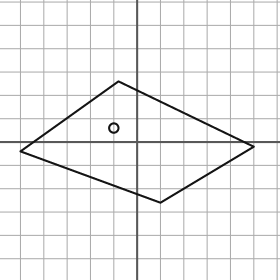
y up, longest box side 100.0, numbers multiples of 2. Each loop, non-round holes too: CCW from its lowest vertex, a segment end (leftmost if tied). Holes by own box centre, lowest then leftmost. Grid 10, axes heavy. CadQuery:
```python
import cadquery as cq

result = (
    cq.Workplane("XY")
    .moveTo(10.0, -26.0)
    .lineTo(50.0, -2.0)
    .lineTo(-8.0, 26.0)
    .lineTo(-50.0, -4.0)
    .close()
    .moveTo(-10.0, 6.0)
    .circle(2.0)
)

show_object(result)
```